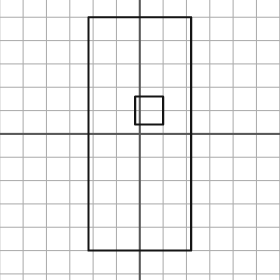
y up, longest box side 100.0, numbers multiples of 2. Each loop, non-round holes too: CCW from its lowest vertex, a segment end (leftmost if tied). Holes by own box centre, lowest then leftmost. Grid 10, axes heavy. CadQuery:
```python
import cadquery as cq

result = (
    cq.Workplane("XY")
    .moveTo(-22.0, -50.0)
    .lineTo(22.0, -50.0)
    .lineTo(22.0, 50.0)
    .lineTo(-22.0, 50.0)
    .close()
    .moveTo(-2.0, 4.0)
    .lineTo(10.0, 4.0)
    .lineTo(10.0, 16.0)
    .lineTo(-2.0, 16.0)
    .close()
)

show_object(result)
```